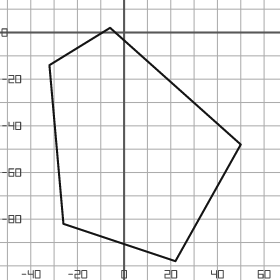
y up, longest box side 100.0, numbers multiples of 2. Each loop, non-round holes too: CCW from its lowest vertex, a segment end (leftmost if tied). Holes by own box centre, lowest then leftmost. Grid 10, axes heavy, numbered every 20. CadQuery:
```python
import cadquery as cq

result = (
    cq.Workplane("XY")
    .moveTo(22.0, -98.0)
    .lineTo(50.0, -48.0)
    .lineTo(-6.0, 2.0)
    .lineTo(-32.0, -14.0)
    .lineTo(-26.0, -82.0)
    .close()
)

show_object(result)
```